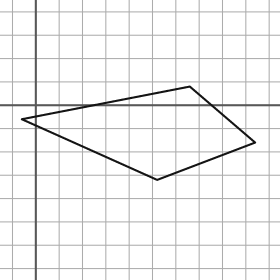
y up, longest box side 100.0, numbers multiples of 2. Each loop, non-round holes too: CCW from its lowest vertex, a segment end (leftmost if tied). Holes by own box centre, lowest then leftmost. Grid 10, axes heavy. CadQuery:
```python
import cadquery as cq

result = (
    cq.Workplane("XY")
    .moveTo(52.0, -32.0)
    .lineTo(94.0, -16.0)
    .lineTo(66.0, 8.0)
    .lineTo(-6.0, -6.0)
    .close()
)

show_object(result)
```